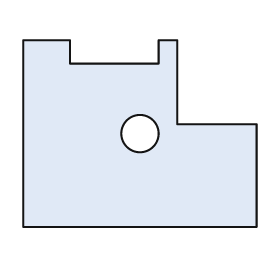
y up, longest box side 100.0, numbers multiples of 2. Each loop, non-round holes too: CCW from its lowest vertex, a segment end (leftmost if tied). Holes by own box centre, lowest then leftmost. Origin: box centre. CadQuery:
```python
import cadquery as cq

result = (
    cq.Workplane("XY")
    .moveTo(-50.0, -40.0)
    .lineTo(50.0, -40.0)
    .lineTo(50.0, 4.0)
    .lineTo(16.0, 4.0)
    .lineTo(16.0, 40.0)
    .lineTo(8.0, 40.0)
    .lineTo(8.0, 30.0)
    .lineTo(-30.0, 30.0)
    .lineTo(-30.0, 40.0)
    .lineTo(-50.0, 40.0)
    .close()
    .moveTo(0.0, 0.0)
    .circle(8.0)
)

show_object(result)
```